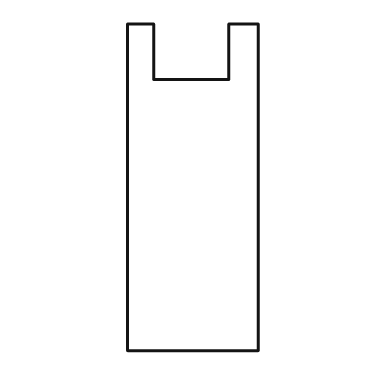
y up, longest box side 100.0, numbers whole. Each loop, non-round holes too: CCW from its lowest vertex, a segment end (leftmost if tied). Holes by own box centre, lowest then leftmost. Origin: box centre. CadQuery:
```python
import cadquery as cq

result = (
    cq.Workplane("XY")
    .moveTo(-20.0, -50.0)
    .lineTo(20.0, -50.0)
    .lineTo(20.0, 50.0)
    .lineTo(11.0, 50.0)
    .lineTo(11.0, 33.0)
    .lineTo(-12.0, 33.0)
    .lineTo(-12.0, 50.0)
    .lineTo(-20.0, 50.0)
    .close()
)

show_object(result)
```